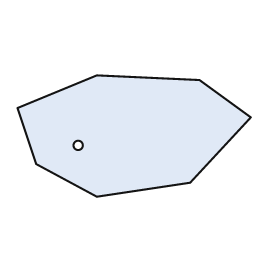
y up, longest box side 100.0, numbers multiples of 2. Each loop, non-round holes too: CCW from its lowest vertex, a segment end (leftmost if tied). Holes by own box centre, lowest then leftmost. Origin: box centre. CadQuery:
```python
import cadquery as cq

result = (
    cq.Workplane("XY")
    .moveTo(-16.0, -26.0)
    .lineTo(24.0, -20.0)
    .lineTo(50.0, 8.0)
    .lineTo(28.0, 24.0)
    .lineTo(-16.0, 26.0)
    .lineTo(-50.0, 12.0)
    .lineTo(-42.0, -12.0)
    .close()
    .moveTo(-24.0, -4.0)
    .circle(2.0)
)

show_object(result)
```